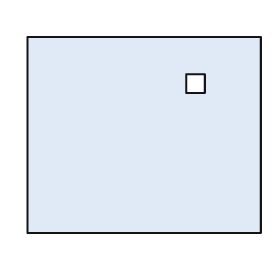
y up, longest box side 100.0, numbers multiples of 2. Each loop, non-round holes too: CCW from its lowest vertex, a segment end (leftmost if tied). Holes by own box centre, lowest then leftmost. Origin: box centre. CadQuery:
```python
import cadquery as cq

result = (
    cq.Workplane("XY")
    .moveTo(-50.0, -42.0)
    .lineTo(50.0, -42.0)
    .lineTo(50.0, 42.0)
    .lineTo(-50.0, 42.0)
    .close()
    .moveTo(18.0, 18.0)
    .lineTo(26.0, 18.0)
    .lineTo(26.0, 26.0)
    .lineTo(18.0, 26.0)
    .close()
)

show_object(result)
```